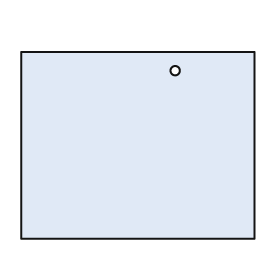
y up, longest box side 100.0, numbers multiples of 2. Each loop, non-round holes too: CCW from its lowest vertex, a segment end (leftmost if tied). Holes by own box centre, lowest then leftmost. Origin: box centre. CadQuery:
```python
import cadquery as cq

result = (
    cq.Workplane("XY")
    .moveTo(-50.0, -40.0)
    .lineTo(50.0, -40.0)
    .lineTo(50.0, 40.0)
    .lineTo(-50.0, 40.0)
    .close()
    .moveTo(16.0, 32.0)
    .circle(2.0)
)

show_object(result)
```